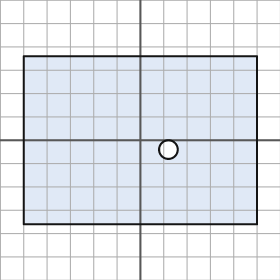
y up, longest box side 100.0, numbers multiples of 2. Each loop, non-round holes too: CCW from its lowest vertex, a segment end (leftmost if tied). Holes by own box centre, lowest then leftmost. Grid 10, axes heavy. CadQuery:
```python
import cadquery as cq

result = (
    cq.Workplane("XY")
    .moveTo(-50.0, -36.0)
    .lineTo(50.0, -36.0)
    .lineTo(50.0, 36.0)
    .lineTo(-50.0, 36.0)
    .close()
    .moveTo(12.0, -4.0)
    .circle(4.0)
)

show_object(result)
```